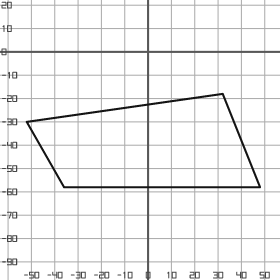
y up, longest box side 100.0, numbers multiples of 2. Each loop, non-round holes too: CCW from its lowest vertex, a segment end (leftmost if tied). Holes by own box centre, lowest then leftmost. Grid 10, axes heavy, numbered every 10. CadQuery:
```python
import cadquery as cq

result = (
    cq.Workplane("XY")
    .moveTo(-36.0, -58.0)
    .lineTo(48.0, -58.0)
    .lineTo(32.0, -18.0)
    .lineTo(-52.0, -30.0)
    .close()
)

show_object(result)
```